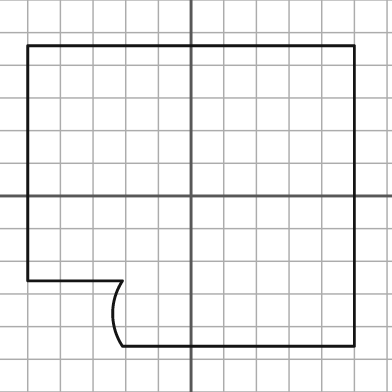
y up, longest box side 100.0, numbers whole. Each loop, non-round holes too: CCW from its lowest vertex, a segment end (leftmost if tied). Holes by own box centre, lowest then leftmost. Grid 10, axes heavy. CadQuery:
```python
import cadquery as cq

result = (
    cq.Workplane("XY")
    .moveTo(-21.0, -46.0)
    .lineTo(50.0, -46.0)
    .lineTo(50.0, 46.0)
    .lineTo(-50.0, 46.0)
    .lineTo(-50.0, -26.0)
    .lineTo(-21.0, -26.0)
    .threePointArc((-24.0, -36.0), (-21.0, -46.0))
    .close()
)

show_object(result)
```